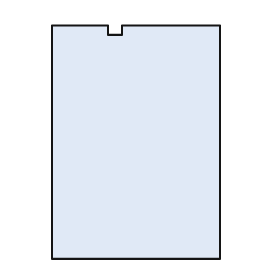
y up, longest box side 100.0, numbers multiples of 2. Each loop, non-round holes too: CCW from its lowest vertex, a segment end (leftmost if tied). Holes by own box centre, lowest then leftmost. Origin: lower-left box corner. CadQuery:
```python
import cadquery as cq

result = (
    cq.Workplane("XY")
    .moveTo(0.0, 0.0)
    .lineTo(72.0, 0.0)
    .lineTo(72.0, 100.0)
    .lineTo(30.0, 100.0)
    .lineTo(30.0, 96.0)
    .lineTo(24.0, 96.0)
    .lineTo(24.0, 100.0)
    .lineTo(0.0, 100.0)
    .close()
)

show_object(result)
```